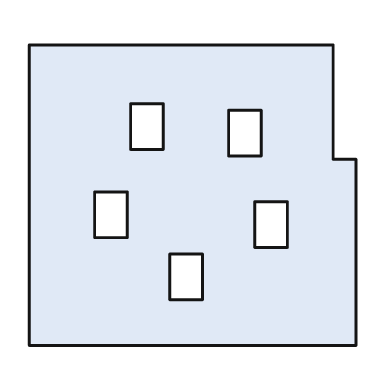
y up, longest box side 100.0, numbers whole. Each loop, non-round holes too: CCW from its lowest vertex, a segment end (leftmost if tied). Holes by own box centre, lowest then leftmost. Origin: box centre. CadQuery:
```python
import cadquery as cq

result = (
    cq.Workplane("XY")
    .moveTo(-50.0, -46.0)
    .lineTo(50.0, -46.0)
    .lineTo(50.0, 11.0)
    .lineTo(43.0, 11.0)
    .lineTo(43.0, 46.0)
    .lineTo(-50.0, 46.0)
    .close()
    .moveTo(-7.0, -32.0)
    .lineTo(3.0, -32.0)
    .lineTo(3.0, -18.0)
    .lineTo(-7.0, -18.0)
    .close()
    .moveTo(19.0, -16.0)
    .lineTo(29.0, -16.0)
    .lineTo(29.0, -2.0)
    .lineTo(19.0, -2.0)
    .close()
    .moveTo(-30.0, -13.0)
    .lineTo(-20.0, -13.0)
    .lineTo(-20.0, 1.0)
    .lineTo(-30.0, 1.0)
    .close()
    .moveTo(11.0, 12.0)
    .lineTo(21.0, 12.0)
    .lineTo(21.0, 26.0)
    .lineTo(11.0, 26.0)
    .close()
    .moveTo(-19.0, 14.0)
    .lineTo(-9.0, 14.0)
    .lineTo(-9.0, 28.0)
    .lineTo(-19.0, 28.0)
    .close()
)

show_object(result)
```